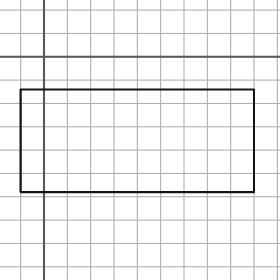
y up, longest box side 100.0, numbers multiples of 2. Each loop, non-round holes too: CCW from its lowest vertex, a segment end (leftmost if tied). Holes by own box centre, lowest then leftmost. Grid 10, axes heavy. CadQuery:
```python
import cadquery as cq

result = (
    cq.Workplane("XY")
    .moveTo(-10.0, -58.0)
    .lineTo(90.0, -58.0)
    .lineTo(90.0, -14.0)
    .lineTo(-10.0, -14.0)
    .close()
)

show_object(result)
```